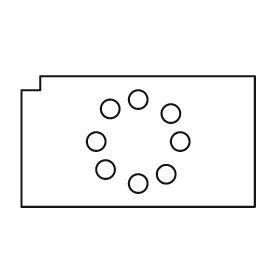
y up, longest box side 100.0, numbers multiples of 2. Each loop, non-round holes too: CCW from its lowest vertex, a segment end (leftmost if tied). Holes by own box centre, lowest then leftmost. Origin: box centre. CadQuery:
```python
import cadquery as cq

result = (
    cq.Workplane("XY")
    .moveTo(-50.0, -28.0)
    .lineTo(50.0, -28.0)
    .lineTo(50.0, 28.0)
    .lineTo(-42.0, 28.0)
    .lineTo(-42.0, 22.0)
    .lineTo(-50.0, 22.0)
    .close()
    .moveTo(0.0, -18.0)
    .circle(4.0)
    .moveTo(12.0, -14.0)
    .circle(4.0)
    .moveTo(-14.0, -12.0)
    .circle(4.0)
    .moveTo(-18.0, 0.0)
    .circle(4.0)
    .moveTo(18.0, 0.0)
    .circle(4.0)
    .moveTo(14.0, 12.0)
    .circle(4.0)
    .moveTo(-12.0, 14.0)
    .circle(4.0)
    .moveTo(0.0, 18.0)
    .circle(4.0)
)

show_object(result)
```